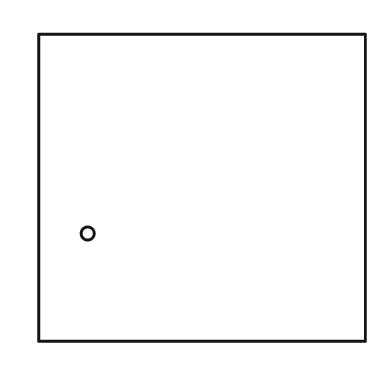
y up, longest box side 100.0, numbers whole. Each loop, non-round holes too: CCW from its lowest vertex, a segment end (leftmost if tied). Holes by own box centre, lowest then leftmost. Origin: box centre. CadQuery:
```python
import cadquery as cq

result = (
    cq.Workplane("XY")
    .moveTo(-50.0, -47.0)
    .lineTo(50.0, -47.0)
    .lineTo(50.0, 47.0)
    .lineTo(-50.0, 47.0)
    .close()
    .moveTo(-35.0, -14.0)
    .circle(2.0)
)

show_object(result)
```